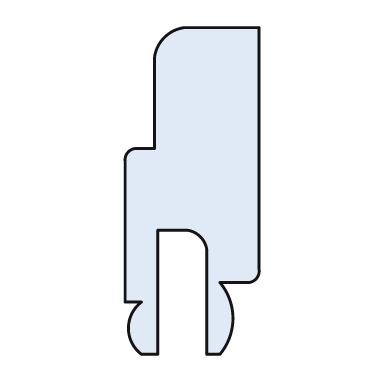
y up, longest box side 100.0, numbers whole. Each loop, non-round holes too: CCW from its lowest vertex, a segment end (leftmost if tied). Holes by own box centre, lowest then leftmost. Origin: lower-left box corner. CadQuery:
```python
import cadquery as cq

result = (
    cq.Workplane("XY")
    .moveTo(5.0, 0.0)
    .lineTo(10.0, 0.0)
    .lineTo(10.0, 38.0)
    .lineTo(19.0, 38.0)
    .threePointArc((23.0, 36.0), (25.0, 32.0))
    .lineTo(25.0, 0.0)
    .lineTo(29.0, 0.0)
    .threePointArc((33.0, 11.0), (29.0, 22.0))
    .lineTo(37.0, 22.0)
    .threePointArc((40.0, 23.0), (41.0, 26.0))
    .lineTo(41.0, 100.0)
    .lineTo(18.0, 100.0)
    .threePointArc((12.0, 97.0), (9.0, 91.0))
    .lineTo(9.0, 63.0)
    .lineTo(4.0, 63.0)
    .threePointArc((1.0, 62.0), (0.0, 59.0))
    .lineTo(0.0, 16.0)
    .lineTo(5.0, 16.0)
    .threePointArc((1.0, 8.0), (5.0, 0.0))
    .close()
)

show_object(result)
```